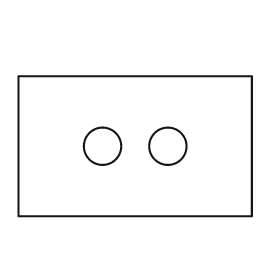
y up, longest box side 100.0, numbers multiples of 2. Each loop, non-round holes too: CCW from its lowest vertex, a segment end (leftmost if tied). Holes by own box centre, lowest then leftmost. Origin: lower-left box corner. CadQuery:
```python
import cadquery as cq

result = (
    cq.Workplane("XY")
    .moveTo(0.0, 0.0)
    .lineTo(100.0, 0.0)
    .lineTo(100.0, 60.0)
    .lineTo(0.0, 60.0)
    .close()
    .moveTo(36.0, 30.0)
    .circle(8.0)
    .moveTo(64.0, 30.0)
    .circle(8.0)
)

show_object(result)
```